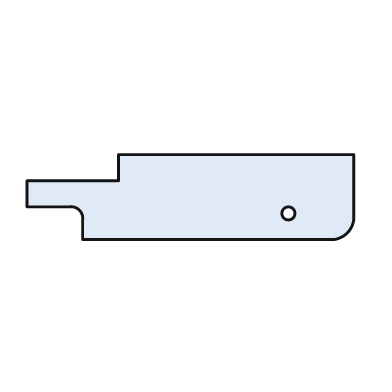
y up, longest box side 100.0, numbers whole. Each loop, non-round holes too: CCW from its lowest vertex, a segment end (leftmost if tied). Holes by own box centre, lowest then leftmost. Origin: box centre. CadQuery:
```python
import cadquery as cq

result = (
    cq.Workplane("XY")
    .moveTo(-33.0, -13.0)
    .lineTo(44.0, -13.0)
    .threePointArc((48.0, -11.0), (50.0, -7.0))
    .lineTo(50.0, 13.0)
    .lineTo(-22.0, 13.0)
    .lineTo(-22.0, 5.0)
    .lineTo(-50.0, 5.0)
    .lineTo(-50.0, -3.0)
    .lineTo(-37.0, -3.0)
    .threePointArc((-34.0, -4.0), (-33.0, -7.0))
    .close()
    .moveTo(30.0, -5.0)
    .circle(2.0)
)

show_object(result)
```